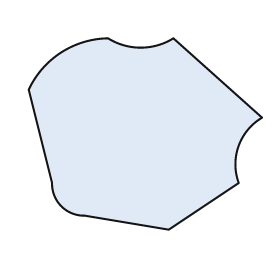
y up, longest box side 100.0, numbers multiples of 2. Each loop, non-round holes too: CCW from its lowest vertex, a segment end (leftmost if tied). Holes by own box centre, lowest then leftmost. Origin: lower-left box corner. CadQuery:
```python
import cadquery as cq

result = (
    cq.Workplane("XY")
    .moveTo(60.0, 0.0)
    .lineTo(90.0, 20.0)
    .threePointArc((90.0, 36.0), (100.0, 48.0))
    .lineTo(62.0, 82.0)
    .threePointArc((48.0, 78.0), (34.0, 82.0))
    .threePointArc((14.0, 76.0), (0.0, 60.0))
    .lineTo(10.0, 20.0)
    .threePointArc((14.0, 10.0), (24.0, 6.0))
    .close()
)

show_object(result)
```